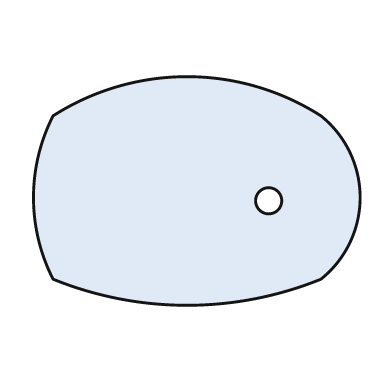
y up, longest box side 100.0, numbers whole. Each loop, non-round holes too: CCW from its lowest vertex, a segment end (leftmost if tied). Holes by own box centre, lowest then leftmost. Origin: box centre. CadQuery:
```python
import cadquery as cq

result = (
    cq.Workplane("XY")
    .moveTo(-44.0, -27.0)
    .threePointArc((-3.0, -35.0), (38.0, -27.0))
    .threePointArc((50.0, -2.0), (38.0, 23.0))
    .threePointArc((-3.0, 35.0), (-44.0, 23.0))
    .threePointArc((-50.0, -2.0), (-44.0, -27.0))
    .close()
    .moveTo(22.0, -3.0)
    .circle(4.0)
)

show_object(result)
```